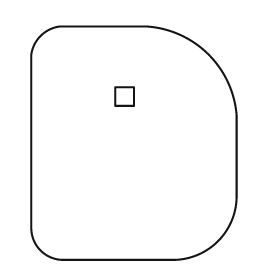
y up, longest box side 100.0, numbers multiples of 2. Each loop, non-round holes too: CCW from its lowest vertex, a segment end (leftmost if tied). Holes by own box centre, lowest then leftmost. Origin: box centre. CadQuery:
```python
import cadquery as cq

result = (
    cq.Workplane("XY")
    .moveTo(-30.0, -50.0)
    .lineTo(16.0, -50.0)
    .threePointArc((36.0, -42.0), (44.0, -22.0))
    .lineTo(44.0, 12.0)
    .threePointArc((32.0, 38.0), (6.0, 50.0))
    .lineTo(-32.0, 50.0)
    .threePointArc((-40.0, 46.0), (-44.0, 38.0))
    .lineTo(-44.0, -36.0)
    .threePointArc((-40.0, -46.0), (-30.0, -50.0))
    .close()
    .moveTo(-8.0, 16.0)
    .lineTo(0.0, 16.0)
    .lineTo(0.0, 24.0)
    .lineTo(-8.0, 24.0)
    .close()
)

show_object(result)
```